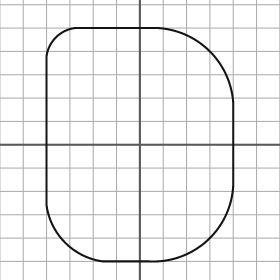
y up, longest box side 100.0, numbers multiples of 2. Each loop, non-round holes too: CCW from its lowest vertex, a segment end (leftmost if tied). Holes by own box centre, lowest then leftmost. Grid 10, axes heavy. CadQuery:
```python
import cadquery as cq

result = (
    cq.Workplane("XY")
    .moveTo(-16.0, -50.0)
    .lineTo(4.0, -50.0)
    .threePointArc((30.0, -40.0), (40.0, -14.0))
    .lineTo(40.0, 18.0)
    .threePointArc((30.0, 40.0), (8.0, 50.0))
    .lineTo(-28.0, 50.0)
    .threePointArc((-36.0, 46.0), (-40.0, 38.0))
    .lineTo(-40.0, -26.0)
    .threePointArc((-32.0, -42.0), (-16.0, -50.0))
    .close()
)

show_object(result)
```